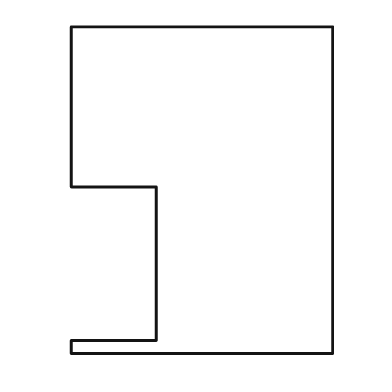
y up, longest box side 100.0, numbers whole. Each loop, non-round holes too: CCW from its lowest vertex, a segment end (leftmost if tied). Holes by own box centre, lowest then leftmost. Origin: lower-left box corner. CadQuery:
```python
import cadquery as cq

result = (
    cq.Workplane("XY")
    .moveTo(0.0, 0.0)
    .lineTo(80.0, 0.0)
    .lineTo(80.0, 100.0)
    .lineTo(0.0, 100.0)
    .lineTo(0.0, 51.0)
    .lineTo(26.0, 51.0)
    .lineTo(26.0, 4.0)
    .lineTo(0.0, 4.0)
    .close()
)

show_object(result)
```